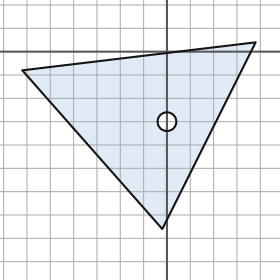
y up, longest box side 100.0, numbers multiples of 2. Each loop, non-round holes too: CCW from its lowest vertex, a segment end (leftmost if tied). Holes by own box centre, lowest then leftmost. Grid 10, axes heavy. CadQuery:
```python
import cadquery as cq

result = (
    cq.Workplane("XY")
    .moveTo(-2.0, -76.0)
    .lineTo(38.0, 4.0)
    .lineTo(-62.0, -8.0)
    .close()
    .moveTo(0.0, -30.0)
    .circle(4.0)
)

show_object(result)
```